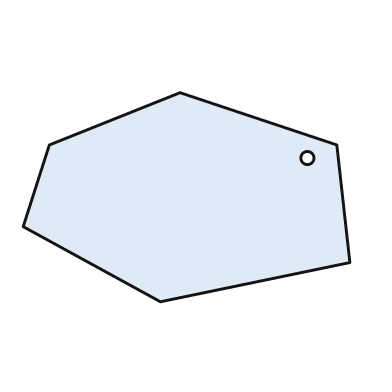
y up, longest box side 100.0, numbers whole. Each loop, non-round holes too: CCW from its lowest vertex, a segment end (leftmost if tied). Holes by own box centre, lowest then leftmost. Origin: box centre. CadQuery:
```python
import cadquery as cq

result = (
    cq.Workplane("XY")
    .moveTo(-8.0, -32.0)
    .lineTo(50.0, -20.0)
    .lineTo(46.0, 16.0)
    .lineTo(-2.0, 32.0)
    .lineTo(-42.0, 16.0)
    .lineTo(-50.0, -9.0)
    .close()
    .moveTo(37.0, 12.0)
    .circle(2.0)
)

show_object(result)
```